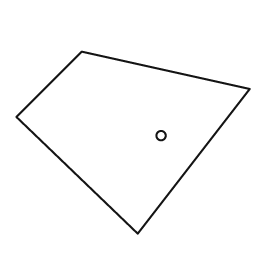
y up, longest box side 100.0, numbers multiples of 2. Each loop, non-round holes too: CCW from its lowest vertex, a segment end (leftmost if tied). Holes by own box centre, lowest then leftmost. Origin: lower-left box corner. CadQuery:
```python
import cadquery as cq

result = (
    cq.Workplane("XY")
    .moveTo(52.0, 0.0)
    .lineTo(100.0, 62.0)
    .lineTo(28.0, 78.0)
    .lineTo(0.0, 50.0)
    .close()
    .moveTo(62.0, 42.0)
    .circle(2.0)
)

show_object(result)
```